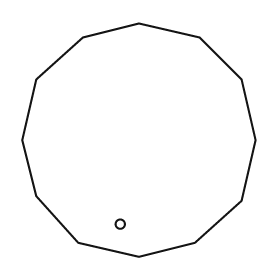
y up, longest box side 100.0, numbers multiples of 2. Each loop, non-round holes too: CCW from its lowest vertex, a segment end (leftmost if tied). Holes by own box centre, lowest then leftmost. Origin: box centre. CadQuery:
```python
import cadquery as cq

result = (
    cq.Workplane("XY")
    .moveTo(0.0, -50.0)
    .lineTo(24.0, -44.0)
    .lineTo(44.0, -26.0)
    .lineTo(50.0, 0.0)
    .lineTo(44.0, 26.0)
    .lineTo(26.0, 44.0)
    .lineTo(0.0, 50.0)
    .lineTo(-24.0, 44.0)
    .lineTo(-44.0, 26.0)
    .lineTo(-50.0, 0.0)
    .lineTo(-44.0, -24.0)
    .lineTo(-26.0, -44.0)
    .close()
    .moveTo(-8.0, -36.0)
    .circle(2.0)
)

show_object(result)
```